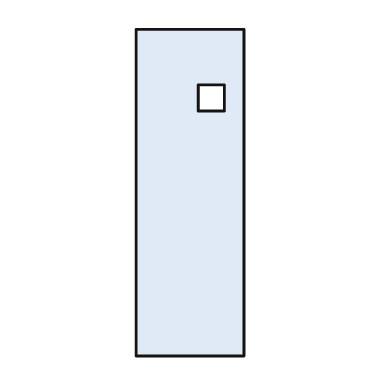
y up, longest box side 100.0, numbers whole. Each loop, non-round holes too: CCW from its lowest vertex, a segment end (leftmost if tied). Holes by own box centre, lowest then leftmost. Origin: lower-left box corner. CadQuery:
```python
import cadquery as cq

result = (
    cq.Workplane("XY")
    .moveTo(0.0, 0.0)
    .lineTo(33.0, 0.0)
    .lineTo(33.0, 100.0)
    .lineTo(0.0, 100.0)
    .close()
    .moveTo(19.0, 75.0)
    .lineTo(27.0, 75.0)
    .lineTo(27.0, 83.0)
    .lineTo(19.0, 83.0)
    .close()
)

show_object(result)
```